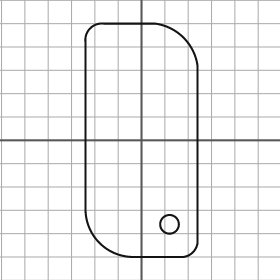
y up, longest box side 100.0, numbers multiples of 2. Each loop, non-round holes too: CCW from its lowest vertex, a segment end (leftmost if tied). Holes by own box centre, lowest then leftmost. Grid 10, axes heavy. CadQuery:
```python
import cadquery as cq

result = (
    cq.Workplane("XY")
    .moveTo(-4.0, -50.0)
    .lineTo(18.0, -50.0)
    .threePointArc((22.0, -48.0), (24.0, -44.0))
    .lineTo(24.0, 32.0)
    .threePointArc((18.0, 44.0), (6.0, 50.0))
    .lineTo(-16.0, 50.0)
    .threePointArc((-22.0, 48.0), (-24.0, 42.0))
    .lineTo(-24.0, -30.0)
    .threePointArc((-18.0, -44.0), (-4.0, -50.0))
    .close()
    .moveTo(12.0, -36.0)
    .circle(4.0)
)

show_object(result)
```